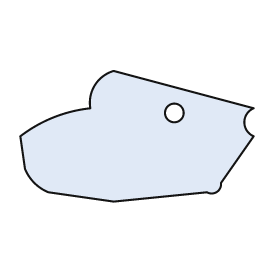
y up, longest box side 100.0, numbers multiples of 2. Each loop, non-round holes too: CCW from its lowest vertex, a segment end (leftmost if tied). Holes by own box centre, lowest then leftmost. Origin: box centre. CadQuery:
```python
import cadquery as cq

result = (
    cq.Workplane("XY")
    .moveTo(-10.0, -28.0)
    .lineTo(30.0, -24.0)
    .threePointArc((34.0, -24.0), (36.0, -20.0))
    .lineTo(50.0, 0.0)
    .threePointArc((46.0, 6.0), (50.0, 12.0))
    .lineTo(-10.0, 28.0)
    .threePointArc((-18.0, 22.0), (-20.0, 12.0))
    .threePointArc((-36.0, 8.0), (-50.0, 0.0))
    .lineTo(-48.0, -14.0)
    .threePointArc((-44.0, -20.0), (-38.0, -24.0))
    .close()
    .moveTo(16.0, 10.0)
    .circle(4.0)
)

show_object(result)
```